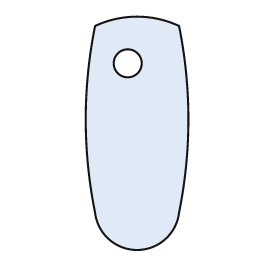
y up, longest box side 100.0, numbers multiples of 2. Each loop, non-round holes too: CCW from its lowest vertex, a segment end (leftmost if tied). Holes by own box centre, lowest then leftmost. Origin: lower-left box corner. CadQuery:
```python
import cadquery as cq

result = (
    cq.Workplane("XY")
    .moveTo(4.0, 16.0)
    .threePointArc((22.0, 0.0), (40.0, 16.0))
    .threePointArc((44.0, 56.0), (40.0, 96.0))
    .threePointArc((22.0, 100.0), (4.0, 96.0))
    .threePointArc((0.0, 56.0), (4.0, 16.0))
    .close()
    .moveTo(18.0, 80.0)
    .circle(6.0)
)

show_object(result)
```